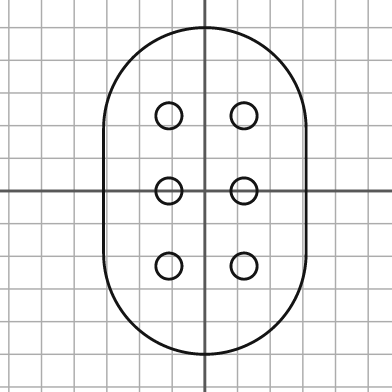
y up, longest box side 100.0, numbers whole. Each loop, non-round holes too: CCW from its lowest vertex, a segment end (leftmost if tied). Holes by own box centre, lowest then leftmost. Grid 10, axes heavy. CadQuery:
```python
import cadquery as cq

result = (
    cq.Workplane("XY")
    .moveTo(-31.0, -19.0)
    .threePointArc((0.0, -50.0), (31.0, -19.0))
    .lineTo(31.0, 19.0)
    .threePointArc((0.0, 50.0), (-31.0, 19.0))
    .close()
    .moveTo(-11.0, -23.0)
    .circle(4.0)
    .moveTo(12.0, -23.0)
    .circle(4.0)
    .moveTo(-11.0, 0.0)
    .circle(4.0)
    .moveTo(12.0, 0.0)
    .circle(4.0)
    .moveTo(-11.0, 23.0)
    .circle(4.0)
    .moveTo(12.0, 23.0)
    .circle(4.0)
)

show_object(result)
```